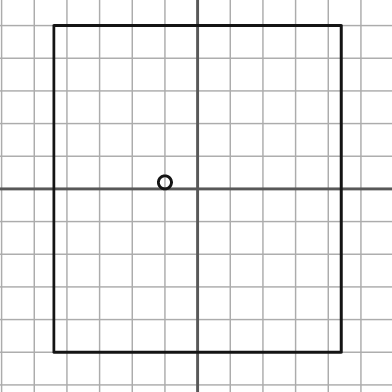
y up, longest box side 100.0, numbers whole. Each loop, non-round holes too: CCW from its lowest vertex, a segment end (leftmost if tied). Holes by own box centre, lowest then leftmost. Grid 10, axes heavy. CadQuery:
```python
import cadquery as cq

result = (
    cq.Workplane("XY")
    .moveTo(-44.0, -50.0)
    .lineTo(44.0, -50.0)
    .lineTo(44.0, 50.0)
    .lineTo(-44.0, 50.0)
    .close()
    .moveTo(-10.0, 2.0)
    .circle(2.0)
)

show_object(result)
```